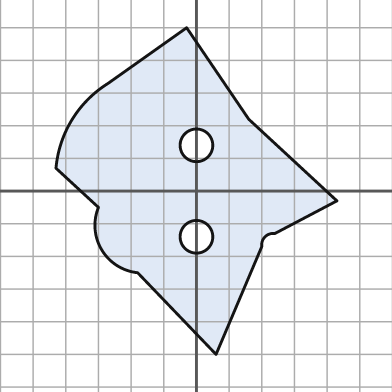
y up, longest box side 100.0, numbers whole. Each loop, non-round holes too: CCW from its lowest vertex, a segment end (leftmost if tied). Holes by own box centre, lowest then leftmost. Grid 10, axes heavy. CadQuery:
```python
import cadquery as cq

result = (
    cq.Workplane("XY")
    .moveTo(6.0, -50.0)
    .lineTo(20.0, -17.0)
    .threePointArc((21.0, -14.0), (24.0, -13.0))
    .lineTo(43.0, -3.0)
    .lineTo(16.0, 22.0)
    .lineTo(-3.0, 50.0)
    .lineTo(-27.0, 33.0)
    .threePointArc((-38.0, 22.0), (-43.0, 7.0))
    .lineTo(-30.0, -5.0)
    .threePointArc((-29.0, -18.0), (-18.0, -25.0))
    .close()
    .moveTo(0.0, -14.0)
    .circle(5.0)
    .moveTo(0.0, 14.0)
    .circle(5.0)
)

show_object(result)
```